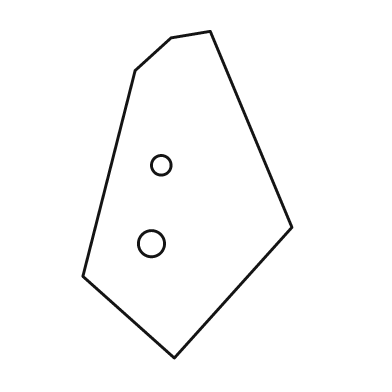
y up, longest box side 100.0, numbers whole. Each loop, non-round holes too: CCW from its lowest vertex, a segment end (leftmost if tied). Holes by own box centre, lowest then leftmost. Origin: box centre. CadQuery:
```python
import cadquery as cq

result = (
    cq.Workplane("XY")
    .moveTo(-4.0, -50.0)
    .lineTo(32.0, -10.0)
    .lineTo(7.0, 50.0)
    .lineTo(-5.0, 48.0)
    .lineTo(-16.0, 38.0)
    .lineTo(-32.0, -25.0)
    .close()
    .moveTo(-11.0, -15.0)
    .circle(4.0)
    .moveTo(-8.0, 9.0)
    .circle(3.0)
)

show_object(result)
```